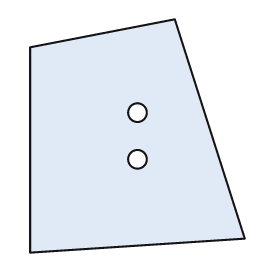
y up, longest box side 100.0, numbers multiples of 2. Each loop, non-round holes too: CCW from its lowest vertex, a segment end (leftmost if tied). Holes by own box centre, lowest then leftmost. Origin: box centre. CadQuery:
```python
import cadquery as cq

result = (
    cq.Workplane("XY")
    .moveTo(-46.0, -50.0)
    .lineTo(46.0, -44.0)
    .lineTo(16.0, 50.0)
    .lineTo(-46.0, 38.0)
    .close()
    .moveTo(0.0, -10.0)
    .circle(4.0)
    .moveTo(0.0, 10.0)
    .circle(4.0)
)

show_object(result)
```